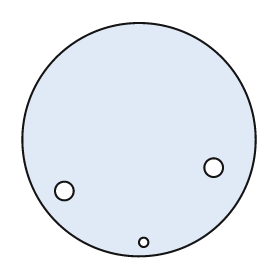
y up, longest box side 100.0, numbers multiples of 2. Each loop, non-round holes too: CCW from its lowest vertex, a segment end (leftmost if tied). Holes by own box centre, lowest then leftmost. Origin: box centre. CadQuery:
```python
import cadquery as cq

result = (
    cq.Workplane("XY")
    .moveTo(0.0, 0.0)
    .circle(50.0)
    .moveTo(2.0, -44.0)
    .circle(2.0)
    .moveTo(-32.0, -22.0)
    .circle(4.0)
    .moveTo(32.0, -12.0)
    .circle(4.0)
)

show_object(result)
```